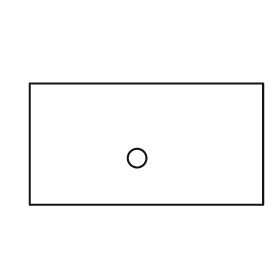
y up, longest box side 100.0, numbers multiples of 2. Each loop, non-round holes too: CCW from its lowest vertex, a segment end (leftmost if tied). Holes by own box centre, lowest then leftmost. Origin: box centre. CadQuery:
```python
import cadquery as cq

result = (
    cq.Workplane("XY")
    .moveTo(-50.0, -26.0)
    .lineTo(50.0, -26.0)
    .lineTo(50.0, 26.0)
    .lineTo(-50.0, 26.0)
    .close()
    .moveTo(-4.0, -6.0)
    .circle(4.0)
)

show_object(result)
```